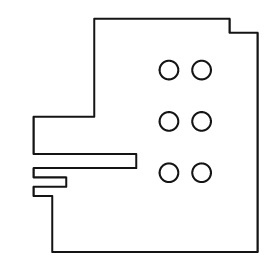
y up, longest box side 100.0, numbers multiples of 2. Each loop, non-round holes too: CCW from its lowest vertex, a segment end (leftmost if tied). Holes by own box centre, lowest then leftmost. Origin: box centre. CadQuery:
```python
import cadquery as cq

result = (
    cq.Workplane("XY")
    .moveTo(-40.0, -50.0)
    .lineTo(48.0, -50.0)
    .lineTo(48.0, 44.0)
    .lineTo(36.0, 44.0)
    .lineTo(36.0, 50.0)
    .lineTo(-22.0, 50.0)
    .lineTo(-22.0, 8.0)
    .lineTo(-48.0, 8.0)
    .lineTo(-48.0, -8.0)
    .lineTo(-4.0, -8.0)
    .lineTo(-4.0, -14.0)
    .lineTo(-48.0, -14.0)
    .lineTo(-48.0, -18.0)
    .lineTo(-34.0, -18.0)
    .lineTo(-34.0, -22.0)
    .lineTo(-48.0, -22.0)
    .lineTo(-48.0, -26.0)
    .lineTo(-40.0, -26.0)
    .close()
    .moveTo(10.0, -16.0)
    .circle(4.0)
    .moveTo(24.0, -16.0)
    .circle(4.0)
    .moveTo(10.0, 6.0)
    .circle(4.0)
    .moveTo(24.0, 6.0)
    .circle(4.0)
    .moveTo(10.0, 28.0)
    .circle(4.0)
    .moveTo(24.0, 28.0)
    .circle(4.0)
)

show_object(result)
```